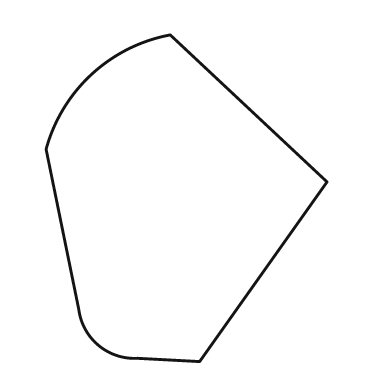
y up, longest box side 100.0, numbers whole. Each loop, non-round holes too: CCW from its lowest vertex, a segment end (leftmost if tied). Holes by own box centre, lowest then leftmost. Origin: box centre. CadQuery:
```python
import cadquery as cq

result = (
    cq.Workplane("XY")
    .moveTo(4.0, -50.0)
    .lineTo(43.0, 5.0)
    .lineTo(-5.0, 50.0)
    .threePointArc((-29.0, 38.0), (-43.0, 15.0))
    .lineTo(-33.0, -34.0)
    .threePointArc((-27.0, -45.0), (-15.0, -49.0))
    .close()
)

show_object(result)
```